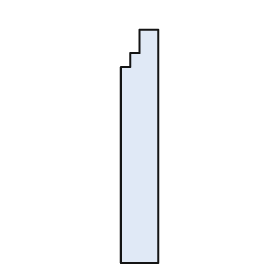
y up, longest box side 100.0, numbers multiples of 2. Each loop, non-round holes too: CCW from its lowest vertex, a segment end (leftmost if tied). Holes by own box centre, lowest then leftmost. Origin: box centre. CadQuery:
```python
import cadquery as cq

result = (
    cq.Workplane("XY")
    .moveTo(-8.0, -50.0)
    .lineTo(8.0, -50.0)
    .lineTo(8.0, 50.0)
    .lineTo(0.0, 50.0)
    .lineTo(0.0, 40.0)
    .lineTo(-4.0, 40.0)
    .lineTo(-4.0, 34.0)
    .lineTo(-8.0, 34.0)
    .close()
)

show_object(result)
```